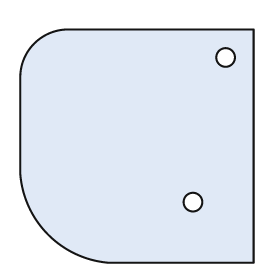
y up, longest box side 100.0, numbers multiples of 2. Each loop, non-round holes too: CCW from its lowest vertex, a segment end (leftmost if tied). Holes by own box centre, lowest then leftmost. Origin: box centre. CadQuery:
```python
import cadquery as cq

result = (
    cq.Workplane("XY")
    .moveTo(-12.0, -50.0)
    .lineTo(50.0, -50.0)
    .lineTo(50.0, 50.0)
    .lineTo(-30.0, 50.0)
    .threePointArc((-44.0, 44.0), (-50.0, 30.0))
    .lineTo(-50.0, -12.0)
    .threePointArc((-38.0, -38.0), (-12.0, -50.0))
    .close()
    .moveTo(24.0, -24.0)
    .circle(4.0)
    .moveTo(38.0, 38.0)
    .circle(4.0)
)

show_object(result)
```